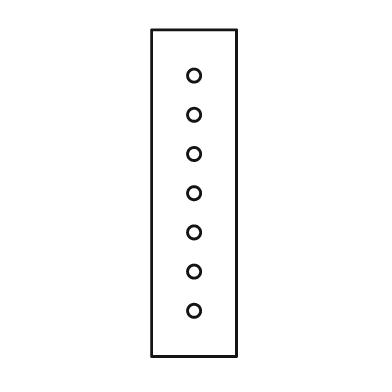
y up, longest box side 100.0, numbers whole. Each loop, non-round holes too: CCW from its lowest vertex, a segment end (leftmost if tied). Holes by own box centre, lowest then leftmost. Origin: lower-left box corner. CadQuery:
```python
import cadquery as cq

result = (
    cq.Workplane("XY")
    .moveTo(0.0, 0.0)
    .lineTo(26.0, 0.0)
    .lineTo(26.0, 100.0)
    .lineTo(0.0, 100.0)
    .close()
    .moveTo(13.0, 14.0)
    .circle(2.0)
    .moveTo(13.0, 26.0)
    .circle(2.0)
    .moveTo(13.0, 38.0)
    .circle(2.0)
    .moveTo(13.0, 50.0)
    .circle(2.0)
    .moveTo(13.0, 62.0)
    .circle(2.0)
    .moveTo(13.0, 74.0)
    .circle(2.0)
    .moveTo(13.0, 86.0)
    .circle(2.0)
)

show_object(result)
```